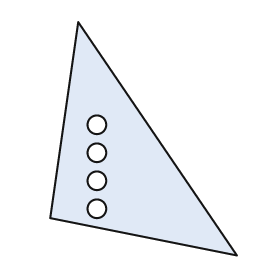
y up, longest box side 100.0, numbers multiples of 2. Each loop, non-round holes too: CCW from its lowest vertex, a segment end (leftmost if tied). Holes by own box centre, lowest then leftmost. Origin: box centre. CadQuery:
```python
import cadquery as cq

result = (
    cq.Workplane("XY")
    .moveTo(40.0, -50.0)
    .lineTo(-28.0, 50.0)
    .lineTo(-40.0, -34.0)
    .close()
    .moveTo(-20.0, -30.0)
    .circle(4.0)
    .moveTo(-20.0, -18.0)
    .circle(4.0)
    .moveTo(-20.0, -6.0)
    .circle(4.0)
    .moveTo(-20.0, 6.0)
    .circle(4.0)
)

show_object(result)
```